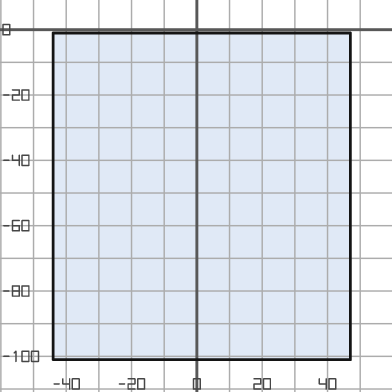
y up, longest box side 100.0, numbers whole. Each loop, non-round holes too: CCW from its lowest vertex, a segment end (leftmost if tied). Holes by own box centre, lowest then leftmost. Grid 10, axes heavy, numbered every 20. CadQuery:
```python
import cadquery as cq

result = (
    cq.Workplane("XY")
    .moveTo(-44.0, -101.0)
    .lineTo(47.0, -101.0)
    .lineTo(47.0, -1.0)
    .lineTo(-44.0, -1.0)
    .close()
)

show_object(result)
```